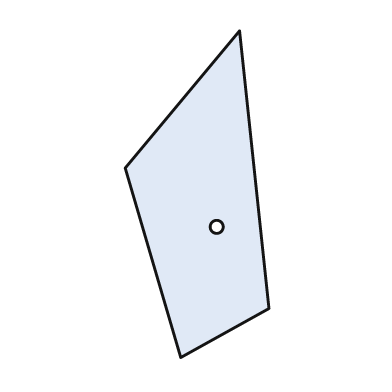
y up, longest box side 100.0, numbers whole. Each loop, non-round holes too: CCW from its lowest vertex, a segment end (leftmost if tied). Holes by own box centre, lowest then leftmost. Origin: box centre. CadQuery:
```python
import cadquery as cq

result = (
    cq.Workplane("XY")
    .moveTo(-5.0, -50.0)
    .lineTo(22.0, -35.0)
    .lineTo(13.0, 50.0)
    .lineTo(-22.0, 8.0)
    .close()
    .moveTo(6.0, -10.0)
    .circle(2.0)
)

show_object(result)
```